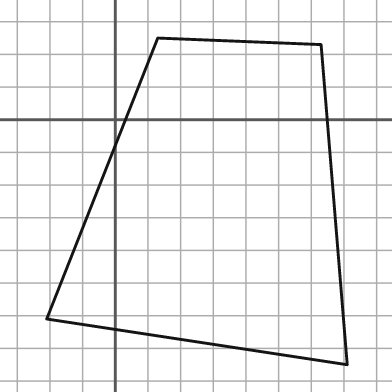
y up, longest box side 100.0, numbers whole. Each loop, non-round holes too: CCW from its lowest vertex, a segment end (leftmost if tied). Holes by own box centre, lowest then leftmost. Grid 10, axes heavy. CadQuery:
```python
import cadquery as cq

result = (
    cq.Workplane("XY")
    .moveTo(71.0, -75.0)
    .lineTo(63.0, 23.0)
    .lineTo(13.0, 25.0)
    .lineTo(-21.0, -61.0)
    .close()
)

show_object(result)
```